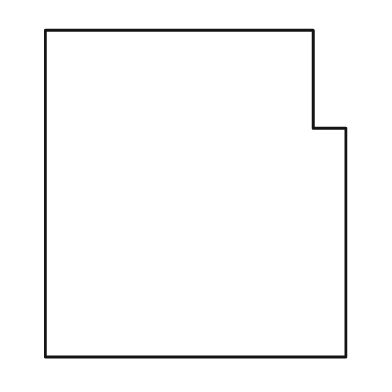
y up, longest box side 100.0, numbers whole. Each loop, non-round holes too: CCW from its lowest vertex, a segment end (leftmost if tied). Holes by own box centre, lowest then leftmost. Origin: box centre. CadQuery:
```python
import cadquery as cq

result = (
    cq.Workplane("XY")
    .moveTo(-46.0, -50.0)
    .lineTo(46.0, -50.0)
    .lineTo(46.0, 20.0)
    .lineTo(36.0, 20.0)
    .lineTo(36.0, 50.0)
    .lineTo(-46.0, 50.0)
    .close()
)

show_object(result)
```